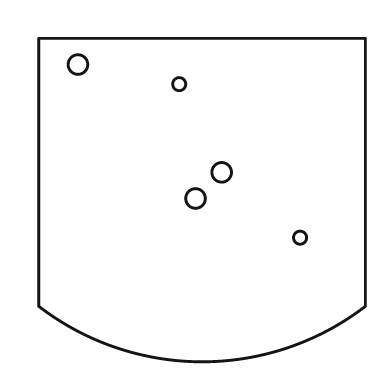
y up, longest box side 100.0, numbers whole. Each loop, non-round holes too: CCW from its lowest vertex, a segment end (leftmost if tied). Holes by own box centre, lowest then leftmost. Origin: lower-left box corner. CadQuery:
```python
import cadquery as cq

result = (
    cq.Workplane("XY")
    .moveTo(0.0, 17.0)
    .threePointArc((50.0, 0.0), (100.0, 17.0))
    .lineTo(100.0, 99.0)
    .lineTo(0.0, 99.0)
    .close()
    .moveTo(80.0, 38.0)
    .circle(2.0)
    .moveTo(48.0, 50.0)
    .circle(3.0)
    .moveTo(56.0, 58.0)
    .circle(3.0)
    .moveTo(43.0, 85.0)
    .circle(2.0)
    .moveTo(12.0, 91.0)
    .circle(3.0)
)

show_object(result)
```